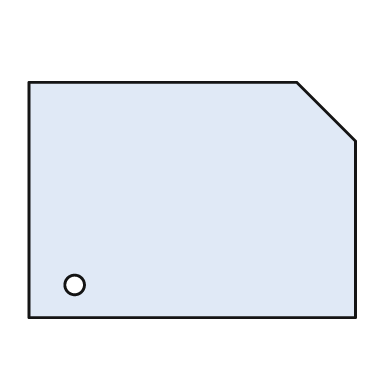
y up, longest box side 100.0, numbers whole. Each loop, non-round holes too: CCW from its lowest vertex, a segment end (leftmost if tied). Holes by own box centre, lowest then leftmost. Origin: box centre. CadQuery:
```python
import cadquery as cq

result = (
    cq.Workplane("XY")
    .moveTo(-50.0, -36.0)
    .lineTo(50.0, -36.0)
    .lineTo(50.0, 18.0)
    .lineTo(32.0, 36.0)
    .lineTo(-50.0, 36.0)
    .close()
    .moveTo(-36.0, -26.0)
    .circle(3.0)
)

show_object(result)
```